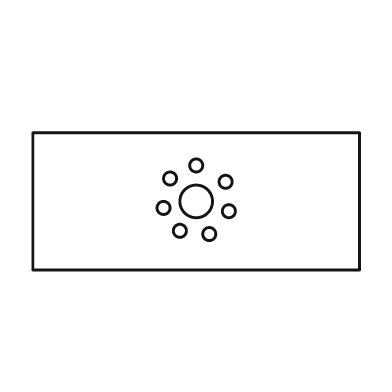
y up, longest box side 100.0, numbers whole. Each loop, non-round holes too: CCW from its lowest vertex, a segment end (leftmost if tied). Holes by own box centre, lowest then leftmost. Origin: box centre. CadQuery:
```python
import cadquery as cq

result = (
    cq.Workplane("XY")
    .moveTo(-50.0, -21.0)
    .lineTo(50.0, -21.0)
    .lineTo(50.0, 21.0)
    .lineTo(-50.0, 21.0)
    .close()
    .moveTo(4.0, -10.0)
    .circle(2.0)
    .moveTo(-5.0, -9.0)
    .circle(2.0)
    .moveTo(10.0, -3.0)
    .circle(2.0)
    .moveTo(-10.0, -2.0)
    .circle(2.0)
    .moveTo(0.0, 0.0)
    .circle(5.0)
    .moveTo(9.0, 6.0)
    .circle(2.0)
    .moveTo(-8.0, 7.0)
    .circle(2.0)
    .moveTo(0.0, 11.0)
    .circle(2.0)
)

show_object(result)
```